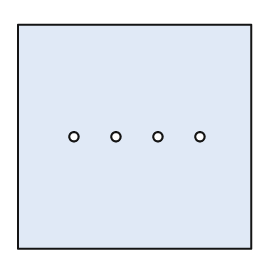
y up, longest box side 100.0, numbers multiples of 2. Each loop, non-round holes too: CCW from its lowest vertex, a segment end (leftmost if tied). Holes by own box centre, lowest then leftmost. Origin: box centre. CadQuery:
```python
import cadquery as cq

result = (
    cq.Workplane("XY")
    .moveTo(-50.0, -48.0)
    .lineTo(50.0, -48.0)
    .lineTo(50.0, 48.0)
    .lineTo(-50.0, 48.0)
    .close()
    .moveTo(-26.0, 0.0)
    .circle(2.0)
    .moveTo(-8.0, 0.0)
    .circle(2.0)
    .moveTo(10.0, 0.0)
    .circle(2.0)
    .moveTo(28.0, 0.0)
    .circle(2.0)
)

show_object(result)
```